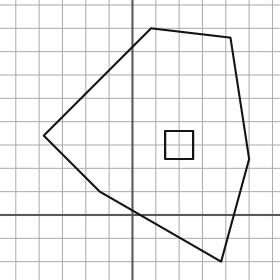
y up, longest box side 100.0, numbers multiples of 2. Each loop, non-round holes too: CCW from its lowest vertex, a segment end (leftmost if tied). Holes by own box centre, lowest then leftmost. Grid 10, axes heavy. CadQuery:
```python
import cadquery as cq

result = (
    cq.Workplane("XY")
    .moveTo(38.0, -20.0)
    .lineTo(50.0, 24.0)
    .lineTo(42.0, 76.0)
    .lineTo(8.0, 80.0)
    .lineTo(-38.0, 34.0)
    .lineTo(-14.0, 10.0)
    .close()
    .moveTo(14.0, 24.0)
    .lineTo(26.0, 24.0)
    .lineTo(26.0, 36.0)
    .lineTo(14.0, 36.0)
    .close()
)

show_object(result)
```